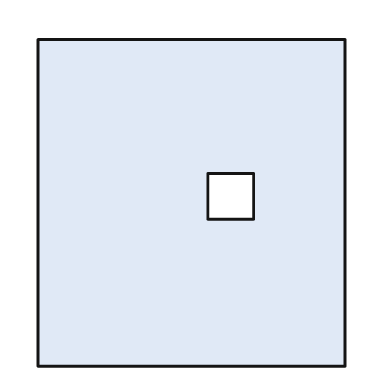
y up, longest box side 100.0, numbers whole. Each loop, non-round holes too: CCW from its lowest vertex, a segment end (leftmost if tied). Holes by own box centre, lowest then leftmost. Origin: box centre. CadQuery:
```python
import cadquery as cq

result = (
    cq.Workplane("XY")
    .moveTo(-47.0, -50.0)
    .lineTo(47.0, -50.0)
    .lineTo(47.0, 50.0)
    .lineTo(-47.0, 50.0)
    .close()
    .moveTo(5.0, -5.0)
    .lineTo(19.0, -5.0)
    .lineTo(19.0, 9.0)
    .lineTo(5.0, 9.0)
    .close()
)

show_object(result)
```